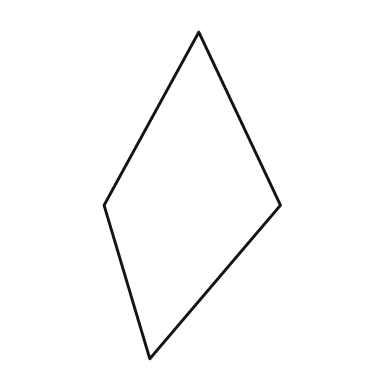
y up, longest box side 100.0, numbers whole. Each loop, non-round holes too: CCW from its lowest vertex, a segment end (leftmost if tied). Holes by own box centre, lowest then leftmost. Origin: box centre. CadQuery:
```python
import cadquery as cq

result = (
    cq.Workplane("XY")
    .moveTo(-13.0, -50.0)
    .lineTo(27.0, -3.0)
    .lineTo(2.0, 50.0)
    .lineTo(-27.0, -3.0)
    .close()
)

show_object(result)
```